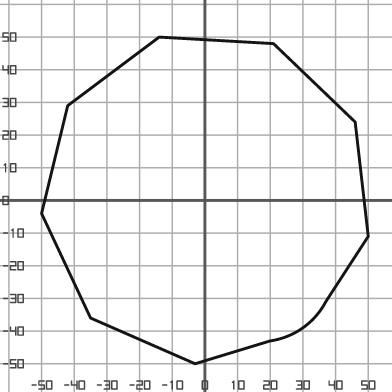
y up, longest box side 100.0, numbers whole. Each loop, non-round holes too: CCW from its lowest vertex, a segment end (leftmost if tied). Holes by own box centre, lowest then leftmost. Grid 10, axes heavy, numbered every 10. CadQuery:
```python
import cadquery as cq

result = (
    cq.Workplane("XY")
    .moveTo(-3.0, -50.0)
    .lineTo(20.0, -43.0)
    .threePointArc((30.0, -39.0), (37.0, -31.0))
    .lineTo(50.0, -11.0)
    .lineTo(46.0, 24.0)
    .lineTo(21.0, 48.0)
    .lineTo(-14.0, 50.0)
    .lineTo(-42.0, 29.0)
    .lineTo(-50.0, -4.0)
    .lineTo(-35.0, -36.0)
    .close()
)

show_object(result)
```